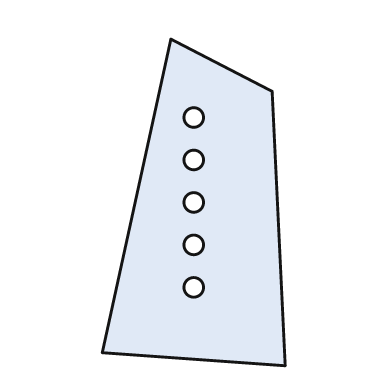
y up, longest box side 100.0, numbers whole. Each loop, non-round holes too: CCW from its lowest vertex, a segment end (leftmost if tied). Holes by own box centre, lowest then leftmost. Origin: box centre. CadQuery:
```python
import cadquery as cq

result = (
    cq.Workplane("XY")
    .moveTo(28.0, -50.0)
    .lineTo(24.0, 34.0)
    .lineTo(-7.0, 50.0)
    .lineTo(-28.0, -46.0)
    .close()
    .moveTo(0.0, -26.0)
    .circle(3.0)
    .moveTo(0.0, -13.0)
    .circle(3.0)
    .moveTo(0.0, 0.0)
    .circle(3.0)
    .moveTo(0.0, 13.0)
    .circle(3.0)
    .moveTo(0.0, 26.0)
    .circle(3.0)
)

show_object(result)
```